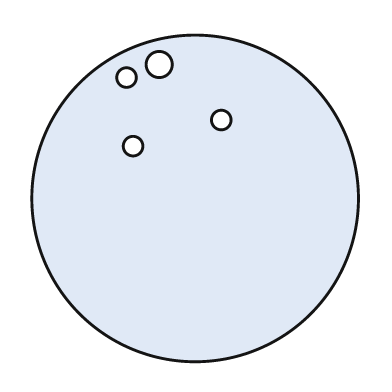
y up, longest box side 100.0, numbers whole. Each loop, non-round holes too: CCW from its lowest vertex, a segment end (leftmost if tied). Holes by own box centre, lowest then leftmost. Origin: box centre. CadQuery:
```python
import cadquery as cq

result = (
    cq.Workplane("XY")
    .moveTo(0.0, 0.0)
    .circle(50.0)
    .moveTo(-19.0, 16.0)
    .circle(3.0)
    .moveTo(8.0, 24.0)
    .circle(3.0)
    .moveTo(-21.0, 37.0)
    .circle(3.0)
    .moveTo(-11.0, 41.0)
    .circle(4.0)
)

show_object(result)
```